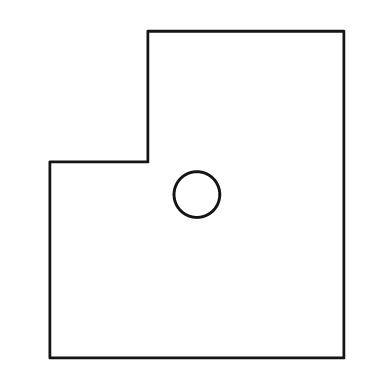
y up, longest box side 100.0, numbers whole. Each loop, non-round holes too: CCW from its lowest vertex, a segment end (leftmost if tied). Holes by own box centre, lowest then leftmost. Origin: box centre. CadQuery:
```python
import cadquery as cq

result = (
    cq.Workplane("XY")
    .moveTo(-45.0, -50.0)
    .lineTo(45.0, -50.0)
    .lineTo(45.0, 50.0)
    .lineTo(-15.0, 50.0)
    .lineTo(-15.0, 10.0)
    .lineTo(-45.0, 10.0)
    .close()
    .moveTo(0.0, 0.0)
    .circle(7.0)
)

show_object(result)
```